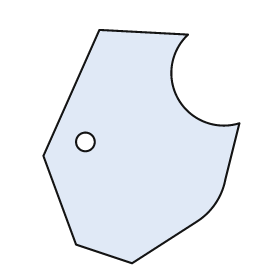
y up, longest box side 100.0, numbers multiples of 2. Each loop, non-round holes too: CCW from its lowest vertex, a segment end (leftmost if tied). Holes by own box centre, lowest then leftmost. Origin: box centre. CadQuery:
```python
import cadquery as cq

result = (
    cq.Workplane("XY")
    .moveTo(-4.0, -50.0)
    .lineTo(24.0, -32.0)
    .threePointArc((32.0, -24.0), (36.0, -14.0))
    .lineTo(42.0, 10.0)
    .threePointArc((16.0, 20.0), (20.0, 48.0))
    .lineTo(-18.0, 50.0)
    .lineTo(-42.0, -4.0)
    .lineTo(-28.0, -42.0)
    .close()
    .moveTo(-24.0, 2.0)
    .circle(4.0)
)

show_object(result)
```